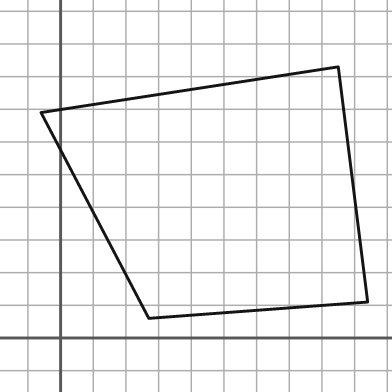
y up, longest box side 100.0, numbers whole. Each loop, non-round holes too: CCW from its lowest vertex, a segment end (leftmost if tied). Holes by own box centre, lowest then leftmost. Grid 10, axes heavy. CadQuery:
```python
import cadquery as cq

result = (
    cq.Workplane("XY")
    .moveTo(27.0, 6.0)
    .lineTo(94.0, 11.0)
    .lineTo(85.0, 83.0)
    .lineTo(-6.0, 69.0)
    .close()
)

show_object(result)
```